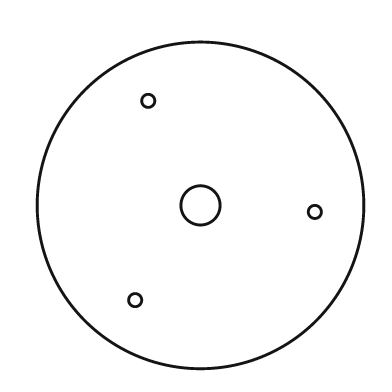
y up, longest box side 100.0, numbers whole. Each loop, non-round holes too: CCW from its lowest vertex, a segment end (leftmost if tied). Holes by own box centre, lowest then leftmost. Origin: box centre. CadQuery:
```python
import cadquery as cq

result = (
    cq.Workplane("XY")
    .moveTo(0.0, 0.0)
    .circle(50.0)
    .moveTo(-20.0, -29.0)
    .circle(2.0)
    .moveTo(35.0, -2.0)
    .circle(2.0)
    .moveTo(0.0, 0.0)
    .circle(6.0)
    .moveTo(-16.0, 32.0)
    .circle(2.0)
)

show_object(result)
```